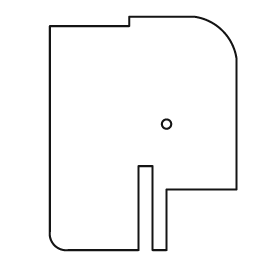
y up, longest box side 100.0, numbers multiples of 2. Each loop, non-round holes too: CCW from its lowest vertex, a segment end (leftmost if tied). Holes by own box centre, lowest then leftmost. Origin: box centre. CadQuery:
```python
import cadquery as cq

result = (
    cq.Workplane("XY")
    .moveTo(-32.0, -50.0)
    .lineTo(-2.0, -50.0)
    .lineTo(-2.0, -14.0)
    .lineTo(4.0, -14.0)
    .lineTo(4.0, -50.0)
    .lineTo(10.0, -50.0)
    .lineTo(10.0, -24.0)
    .lineTo(40.0, -24.0)
    .lineTo(40.0, 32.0)
    .threePointArc((34.0, 44.0), (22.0, 50.0))
    .lineTo(-6.0, 50.0)
    .lineTo(-6.0, 46.0)
    .lineTo(-40.0, 46.0)
    .lineTo(-40.0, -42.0)
    .threePointArc((-38.0, -48.0), (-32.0, -50.0))
    .close()
    .moveTo(10.0, 4.0)
    .circle(2.0)
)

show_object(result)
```